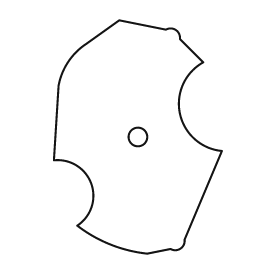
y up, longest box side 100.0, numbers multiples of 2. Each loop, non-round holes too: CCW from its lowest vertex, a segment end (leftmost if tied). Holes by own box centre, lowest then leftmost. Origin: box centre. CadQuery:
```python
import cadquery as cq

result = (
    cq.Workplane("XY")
    .moveTo(4.0, -50.0)
    .lineTo(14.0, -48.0)
    .threePointArc((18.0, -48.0), (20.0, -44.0))
    .lineTo(36.0, -6.0)
    .threePointArc((18.0, 10.0), (28.0, 32.0))
    .lineTo(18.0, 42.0)
    .threePointArc((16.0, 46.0), (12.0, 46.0))
    .lineTo(-8.0, 50.0)
    .lineTo(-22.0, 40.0)
    .threePointArc((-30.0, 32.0), (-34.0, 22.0))
    .lineTo(-36.0, -10.0)
    .threePointArc((-20.0, -20.0), (-26.0, -38.0))
    .threePointArc((-12.0, -46.0), (4.0, -50.0))
    .close()
    .moveTo(0.0, 0.0)
    .circle(4.0)
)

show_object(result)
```